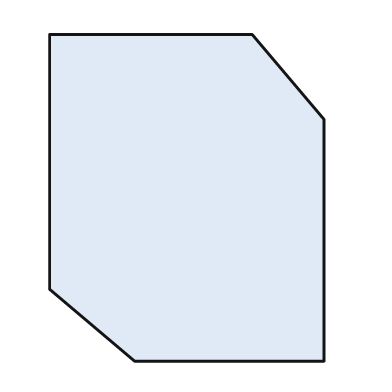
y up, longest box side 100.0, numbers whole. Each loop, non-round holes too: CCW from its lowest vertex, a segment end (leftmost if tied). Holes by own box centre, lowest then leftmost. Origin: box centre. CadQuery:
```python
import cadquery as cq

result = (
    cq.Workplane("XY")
    .moveTo(-16.0, -50.0)
    .lineTo(42.0, -50.0)
    .lineTo(42.0, 24.0)
    .lineTo(20.0, 50.0)
    .lineTo(-42.0, 50.0)
    .lineTo(-42.0, -28.0)
    .close()
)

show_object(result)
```